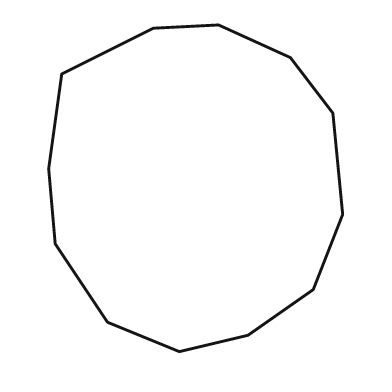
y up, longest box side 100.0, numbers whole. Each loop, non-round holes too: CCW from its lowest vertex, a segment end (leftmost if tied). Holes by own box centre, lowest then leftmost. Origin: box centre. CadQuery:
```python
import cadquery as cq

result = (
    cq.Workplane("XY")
    .moveTo(-5.0, -50.0)
    .lineTo(16.0, -45.0)
    .lineTo(36.0, -31.0)
    .lineTo(45.0, -8.0)
    .lineTo(42.0, 23.0)
    .lineTo(29.0, 40.0)
    .lineTo(7.0, 50.0)
    .lineTo(-13.0, 49.0)
    .lineTo(-41.0, 35.0)
    .lineTo(-45.0, 6.0)
    .lineTo(-43.0, -17.0)
    .lineTo(-27.0, -41.0)
    .close()
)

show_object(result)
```